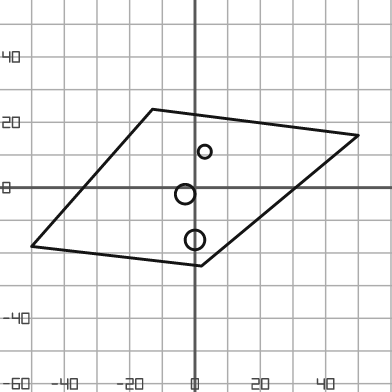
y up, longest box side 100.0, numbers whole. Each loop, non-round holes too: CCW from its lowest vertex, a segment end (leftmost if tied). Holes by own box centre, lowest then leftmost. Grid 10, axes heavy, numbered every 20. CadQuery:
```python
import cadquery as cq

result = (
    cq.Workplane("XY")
    .moveTo(2.0, -24.0)
    .lineTo(50.0, 16.0)
    .lineTo(-13.0, 24.0)
    .lineTo(-50.0, -18.0)
    .close()
    .moveTo(0.0, -16.0)
    .circle(3.0)
    .moveTo(-3.0, -2.0)
    .circle(3.0)
    .moveTo(3.0, 11.0)
    .circle(2.0)
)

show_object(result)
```